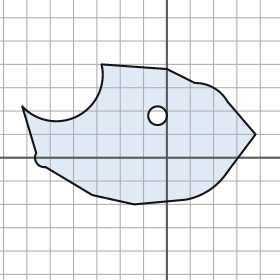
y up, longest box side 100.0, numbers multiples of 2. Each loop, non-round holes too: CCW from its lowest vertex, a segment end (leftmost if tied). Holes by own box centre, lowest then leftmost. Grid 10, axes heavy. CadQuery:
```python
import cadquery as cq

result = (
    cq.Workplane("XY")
    .moveTo(-14.0, -20.0)
    .lineTo(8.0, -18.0)
    .threePointArc((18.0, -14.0), (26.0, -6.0))
    .lineTo(38.0, 10.0)
    .lineTo(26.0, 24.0)
    .threePointArc((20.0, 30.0), (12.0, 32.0))
    .lineTo(0.0, 38.0)
    .lineTo(-28.0, 40.0)
    .threePointArc((-38.0, 18.0), (-62.0, 22.0))
    .lineTo(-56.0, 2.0)
    .threePointArc((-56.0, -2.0), (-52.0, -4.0))
    .lineTo(-32.0, -16.0)
    .close()
    .moveTo(-4.0, 18.0)
    .circle(4.0)
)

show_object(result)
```